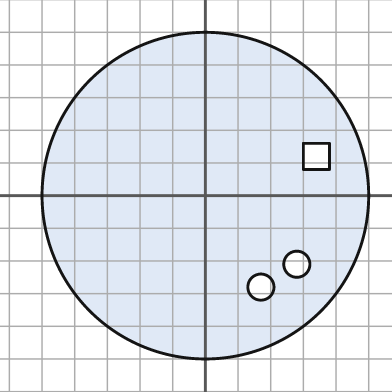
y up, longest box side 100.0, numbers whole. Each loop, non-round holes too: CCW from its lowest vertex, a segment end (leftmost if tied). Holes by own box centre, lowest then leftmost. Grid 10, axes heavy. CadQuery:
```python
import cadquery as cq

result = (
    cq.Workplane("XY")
    .moveTo(0.0, 0.0)
    .circle(50.0)
    .moveTo(17.0, -28.0)
    .circle(4.0)
    .moveTo(28.0, -21.0)
    .circle(4.0)
    .moveTo(30.0, 8.0)
    .lineTo(38.0, 8.0)
    .lineTo(38.0, 16.0)
    .lineTo(30.0, 16.0)
    .close()
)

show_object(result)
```